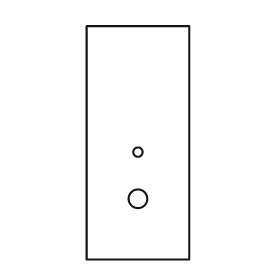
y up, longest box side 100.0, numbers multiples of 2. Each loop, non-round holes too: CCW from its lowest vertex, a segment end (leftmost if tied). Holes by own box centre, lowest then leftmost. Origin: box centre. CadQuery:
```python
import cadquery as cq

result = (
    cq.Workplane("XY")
    .moveTo(-22.0, -50.0)
    .lineTo(22.0, -50.0)
    .lineTo(22.0, 50.0)
    .lineTo(-22.0, 50.0)
    .close()
    .moveTo(0.0, -24.0)
    .circle(4.0)
    .moveTo(0.0, -4.0)
    .circle(2.0)
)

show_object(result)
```